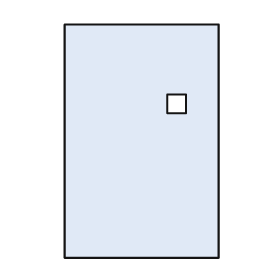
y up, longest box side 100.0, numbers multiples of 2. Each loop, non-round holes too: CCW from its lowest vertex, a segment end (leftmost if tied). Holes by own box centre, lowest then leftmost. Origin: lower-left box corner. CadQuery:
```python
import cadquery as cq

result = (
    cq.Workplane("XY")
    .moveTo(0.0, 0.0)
    .lineTo(66.0, 0.0)
    .lineTo(66.0, 100.0)
    .lineTo(0.0, 100.0)
    .close()
    .moveTo(44.0, 62.0)
    .lineTo(52.0, 62.0)
    .lineTo(52.0, 70.0)
    .lineTo(44.0, 70.0)
    .close()
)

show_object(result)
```